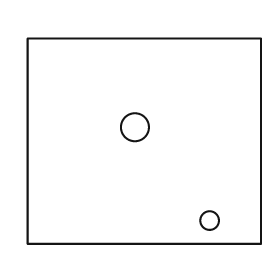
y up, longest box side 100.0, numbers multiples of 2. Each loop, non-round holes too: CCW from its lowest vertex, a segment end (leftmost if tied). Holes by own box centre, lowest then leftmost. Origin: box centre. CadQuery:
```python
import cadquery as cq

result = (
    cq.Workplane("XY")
    .moveTo(-50.0, -44.0)
    .lineTo(50.0, -44.0)
    .lineTo(50.0, 44.0)
    .lineTo(-50.0, 44.0)
    .close()
    .moveTo(28.0, -34.0)
    .circle(4.0)
    .moveTo(-4.0, 6.0)
    .circle(6.0)
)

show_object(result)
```